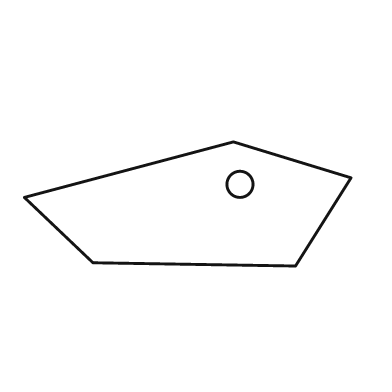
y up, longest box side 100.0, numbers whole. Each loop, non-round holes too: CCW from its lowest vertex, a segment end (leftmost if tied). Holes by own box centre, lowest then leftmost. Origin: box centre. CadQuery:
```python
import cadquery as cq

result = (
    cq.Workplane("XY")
    .moveTo(33.0, -19.0)
    .lineTo(50.0, 8.0)
    .lineTo(14.0, 19.0)
    .lineTo(-50.0, 2.0)
    .lineTo(-29.0, -18.0)
    .close()
    .moveTo(16.0, 6.0)
    .circle(4.0)
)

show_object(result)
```